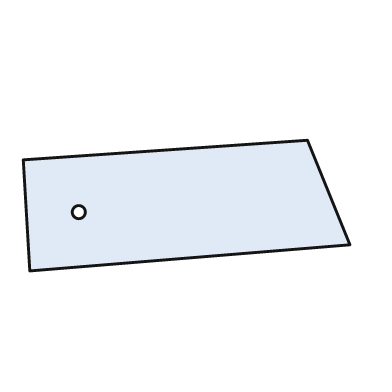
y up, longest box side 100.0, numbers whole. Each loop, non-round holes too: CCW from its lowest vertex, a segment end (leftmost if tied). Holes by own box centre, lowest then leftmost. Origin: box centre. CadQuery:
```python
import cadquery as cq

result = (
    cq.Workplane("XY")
    .moveTo(-48.0, -20.0)
    .lineTo(50.0, -12.0)
    .lineTo(37.0, 20.0)
    .lineTo(-50.0, 14.0)
    .close()
    .moveTo(-33.0, -2.0)
    .circle(2.0)
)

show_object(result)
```